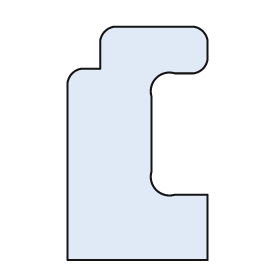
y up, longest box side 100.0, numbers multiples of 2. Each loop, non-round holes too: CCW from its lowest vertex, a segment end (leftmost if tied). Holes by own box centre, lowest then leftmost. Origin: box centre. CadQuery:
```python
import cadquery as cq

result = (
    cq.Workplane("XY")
    .moveTo(-30.0, -50.0)
    .lineTo(30.0, -50.0)
    .lineTo(30.0, -22.0)
    .lineTo(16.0, -22.0)
    .threePointArc((8.0, -20.0), (6.0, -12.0))
    .lineTo(6.0, 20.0)
    .threePointArc((8.0, 28.0), (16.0, 30.0))
    .lineTo(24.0, 30.0)
    .threePointArc((28.0, 32.0), (30.0, 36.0))
    .lineTo(30.0, 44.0)
    .threePointArc((28.0, 48.0), (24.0, 50.0))
    .lineTo(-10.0, 50.0)
    .threePointArc((-14.0, 48.0), (-16.0, 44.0))
    .lineTo(-16.0, 32.0)
    .lineTo(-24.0, 32.0)
    .threePointArc((-28.0, 30.0), (-30.0, 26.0))
    .close()
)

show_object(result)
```